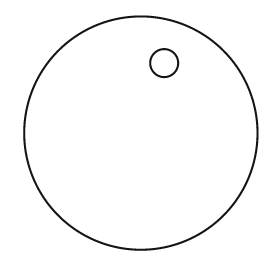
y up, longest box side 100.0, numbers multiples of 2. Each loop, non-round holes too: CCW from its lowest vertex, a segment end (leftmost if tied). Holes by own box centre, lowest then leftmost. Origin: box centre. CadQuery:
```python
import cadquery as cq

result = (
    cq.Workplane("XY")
    .moveTo(0.0, 0.0)
    .circle(50.0)
    .moveTo(10.0, 30.0)
    .circle(6.0)
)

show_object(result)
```